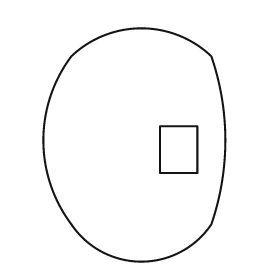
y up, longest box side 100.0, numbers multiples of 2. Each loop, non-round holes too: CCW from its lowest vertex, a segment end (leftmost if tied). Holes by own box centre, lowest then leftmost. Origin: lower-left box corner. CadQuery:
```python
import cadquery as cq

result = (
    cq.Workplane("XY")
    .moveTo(12.0, 16.0)
    .threePointArc((42.0, 0.0), (72.0, 16.0))
    .threePointArc((78.0, 52.0), (72.0, 88.0))
    .threePointArc((42.0, 100.0), (12.0, 88.0))
    .threePointArc((0.0, 52.0), (12.0, 16.0))
    .close()
    .moveTo(50.0, 38.0)
    .lineTo(66.0, 38.0)
    .lineTo(66.0, 58.0)
    .lineTo(50.0, 58.0)
    .close()
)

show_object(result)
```